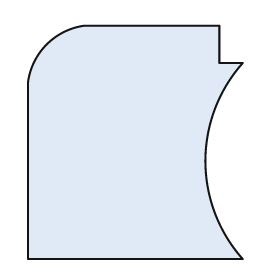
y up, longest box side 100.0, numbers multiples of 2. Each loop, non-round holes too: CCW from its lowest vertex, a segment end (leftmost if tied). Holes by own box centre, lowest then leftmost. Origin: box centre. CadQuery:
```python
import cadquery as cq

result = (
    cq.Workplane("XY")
    .moveTo(-46.0, -50.0)
    .lineTo(46.0, -50.0)
    .threePointArc((30.0, -8.0), (46.0, 34.0))
    .lineTo(36.0, 34.0)
    .lineTo(36.0, 50.0)
    .lineTo(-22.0, 50.0)
    .threePointArc((-38.0, 42.0), (-46.0, 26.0))
    .close()
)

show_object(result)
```